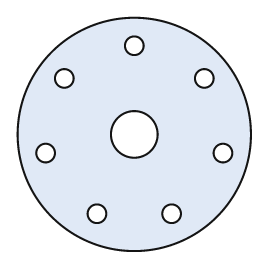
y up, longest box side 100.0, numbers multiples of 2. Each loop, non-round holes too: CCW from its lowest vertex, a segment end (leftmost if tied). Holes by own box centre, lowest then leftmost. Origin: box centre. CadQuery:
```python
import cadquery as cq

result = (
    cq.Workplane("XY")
    .moveTo(0.0, 0.0)
    .circle(50.0)
    .moveTo(-16.0, -34.0)
    .circle(4.0)
    .moveTo(16.0, -34.0)
    .circle(4.0)
    .moveTo(-38.0, -8.0)
    .circle(4.0)
    .moveTo(38.0, -8.0)
    .circle(4.0)
    .moveTo(0.0, 0.0)
    .circle(10.0)
    .moveTo(-30.0, 24.0)
    .circle(4.0)
    .moveTo(30.0, 24.0)
    .circle(4.0)
    .moveTo(0.0, 38.0)
    .circle(4.0)
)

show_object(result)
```